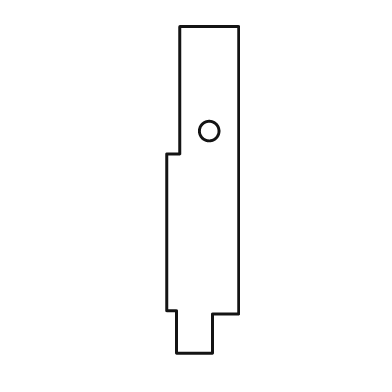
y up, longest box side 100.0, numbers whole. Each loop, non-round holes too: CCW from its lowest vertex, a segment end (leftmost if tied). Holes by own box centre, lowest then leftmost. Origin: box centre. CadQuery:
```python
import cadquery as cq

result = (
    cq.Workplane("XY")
    .moveTo(-8.0, -50.0)
    .lineTo(3.0, -50.0)
    .lineTo(3.0, -38.0)
    .lineTo(11.0, -38.0)
    .lineTo(11.0, 50.0)
    .lineTo(-7.0, 50.0)
    .lineTo(-7.0, 11.0)
    .lineTo(-11.0, 11.0)
    .lineTo(-11.0, -37.0)
    .lineTo(-8.0, -37.0)
    .close()
    .moveTo(2.0, 18.0)
    .circle(3.0)
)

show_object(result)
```